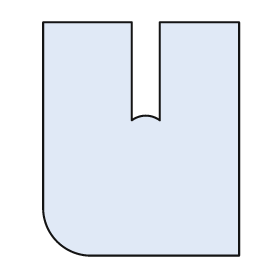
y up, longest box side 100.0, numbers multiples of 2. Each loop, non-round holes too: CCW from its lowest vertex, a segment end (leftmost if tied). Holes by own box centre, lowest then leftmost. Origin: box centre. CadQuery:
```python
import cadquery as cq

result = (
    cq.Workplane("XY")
    .moveTo(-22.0, -50.0)
    .lineTo(42.0, -50.0)
    .lineTo(42.0, 50.0)
    .lineTo(8.0, 50.0)
    .lineTo(8.0, 8.0)
    .threePointArc((2.0, 10.0), (-4.0, 8.0))
    .lineTo(-4.0, 50.0)
    .lineTo(-42.0, 50.0)
    .lineTo(-42.0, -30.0)
    .threePointArc((-36.0, -44.0), (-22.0, -50.0))
    .close()
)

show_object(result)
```